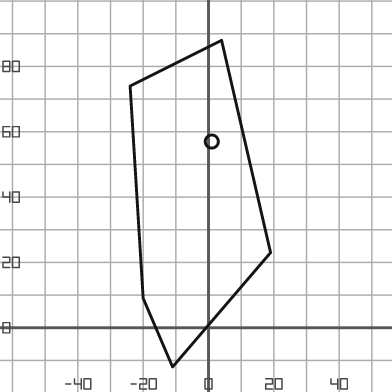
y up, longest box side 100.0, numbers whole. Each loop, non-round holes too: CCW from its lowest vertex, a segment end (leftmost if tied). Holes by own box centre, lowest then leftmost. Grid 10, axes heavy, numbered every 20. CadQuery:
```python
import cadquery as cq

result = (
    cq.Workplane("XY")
    .moveTo(-11.0, -12.0)
    .lineTo(19.0, 23.0)
    .lineTo(4.0, 88.0)
    .lineTo(-24.0, 74.0)
    .lineTo(-20.0, 9.0)
    .close()
    .moveTo(1.0, 57.0)
    .circle(2.0)
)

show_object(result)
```